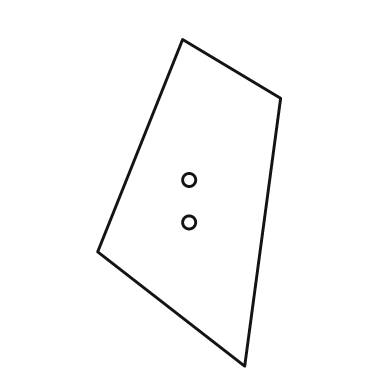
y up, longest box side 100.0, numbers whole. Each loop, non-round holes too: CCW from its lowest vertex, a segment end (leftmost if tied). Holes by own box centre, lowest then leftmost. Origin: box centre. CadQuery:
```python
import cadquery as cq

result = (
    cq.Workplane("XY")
    .moveTo(17.0, -50.0)
    .lineTo(28.0, 32.0)
    .lineTo(-2.0, 50.0)
    .lineTo(-28.0, -15.0)
    .close()
    .moveTo(0.0, -6.0)
    .circle(2.0)
    .moveTo(0.0, 7.0)
    .circle(2.0)
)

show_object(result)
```